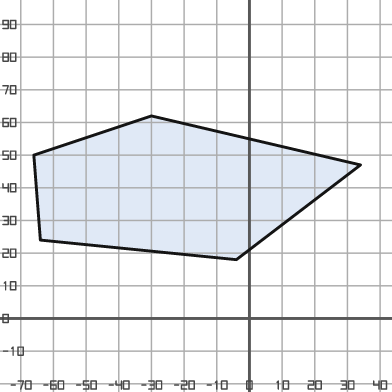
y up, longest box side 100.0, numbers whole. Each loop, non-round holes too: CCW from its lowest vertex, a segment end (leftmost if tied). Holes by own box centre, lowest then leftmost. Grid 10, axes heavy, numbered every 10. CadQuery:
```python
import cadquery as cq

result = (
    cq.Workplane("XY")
    .moveTo(-4.0, 18.0)
    .lineTo(34.0, 47.0)
    .lineTo(-30.0, 62.0)
    .lineTo(-66.0, 50.0)
    .lineTo(-64.0, 24.0)
    .close()
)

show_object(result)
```